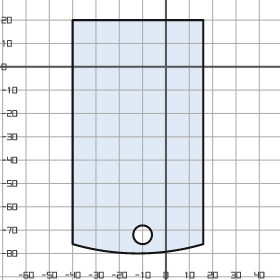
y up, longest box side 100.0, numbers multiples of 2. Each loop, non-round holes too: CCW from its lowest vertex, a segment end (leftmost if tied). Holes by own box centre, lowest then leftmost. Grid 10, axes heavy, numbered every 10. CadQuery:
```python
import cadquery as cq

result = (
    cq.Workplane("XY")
    .moveTo(-40.0, -76.0)
    .threePointArc((-12.0, -80.0), (16.0, -76.0))
    .lineTo(16.0, 20.0)
    .lineTo(-40.0, 20.0)
    .close()
    .moveTo(-10.0, -72.0)
    .circle(4.0)
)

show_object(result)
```